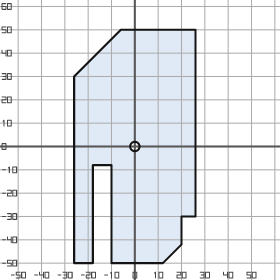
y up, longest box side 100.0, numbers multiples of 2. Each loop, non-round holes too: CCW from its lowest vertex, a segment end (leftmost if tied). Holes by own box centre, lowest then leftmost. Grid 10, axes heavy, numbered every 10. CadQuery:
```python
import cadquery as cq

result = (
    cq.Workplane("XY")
    .moveTo(-26.0, -50.0)
    .lineTo(-18.0, -50.0)
    .lineTo(-18.0, -8.0)
    .lineTo(-10.0, -8.0)
    .lineTo(-10.0, -50.0)
    .lineTo(12.0, -50.0)
    .lineTo(20.0, -42.0)
    .lineTo(20.0, -30.0)
    .lineTo(26.0, -30.0)
    .lineTo(26.0, 50.0)
    .lineTo(-6.0, 50.0)
    .lineTo(-26.0, 30.0)
    .close()
    .moveTo(0.0, 0.0)
    .circle(2.0)
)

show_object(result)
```